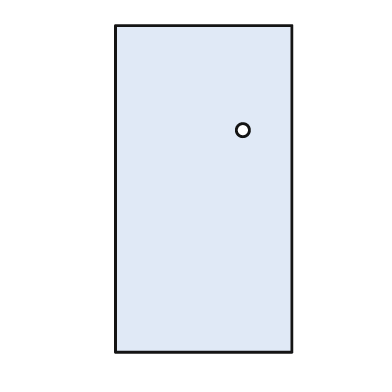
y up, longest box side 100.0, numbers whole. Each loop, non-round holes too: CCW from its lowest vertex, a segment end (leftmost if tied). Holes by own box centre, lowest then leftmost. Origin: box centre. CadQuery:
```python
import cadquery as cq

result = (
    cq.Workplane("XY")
    .moveTo(-27.0, -50.0)
    .lineTo(27.0, -50.0)
    .lineTo(27.0, 50.0)
    .lineTo(-27.0, 50.0)
    .close()
    .moveTo(12.0, 18.0)
    .circle(2.0)
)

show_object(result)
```